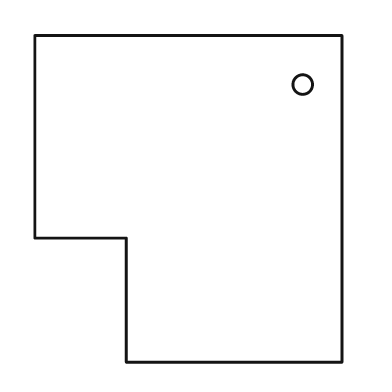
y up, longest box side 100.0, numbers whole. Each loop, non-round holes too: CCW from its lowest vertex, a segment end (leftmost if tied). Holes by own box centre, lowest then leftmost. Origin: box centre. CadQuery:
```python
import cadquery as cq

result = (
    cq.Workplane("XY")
    .moveTo(-19.0, -50.0)
    .lineTo(47.0, -50.0)
    .lineTo(47.0, 50.0)
    .lineTo(-47.0, 50.0)
    .lineTo(-47.0, -12.0)
    .lineTo(-19.0, -12.0)
    .close()
    .moveTo(35.0, 35.0)
    .circle(3.0)
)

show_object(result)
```